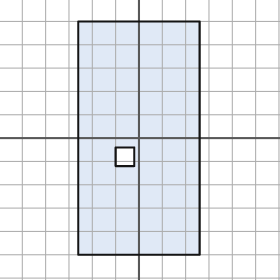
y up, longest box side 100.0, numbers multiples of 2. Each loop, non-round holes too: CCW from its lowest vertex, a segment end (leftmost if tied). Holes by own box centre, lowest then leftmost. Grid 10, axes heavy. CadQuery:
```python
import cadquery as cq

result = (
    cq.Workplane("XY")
    .moveTo(-26.0, -50.0)
    .lineTo(26.0, -50.0)
    .lineTo(26.0, 50.0)
    .lineTo(-26.0, 50.0)
    .close()
    .moveTo(-10.0, -12.0)
    .lineTo(-2.0, -12.0)
    .lineTo(-2.0, -4.0)
    .lineTo(-10.0, -4.0)
    .close()
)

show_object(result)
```